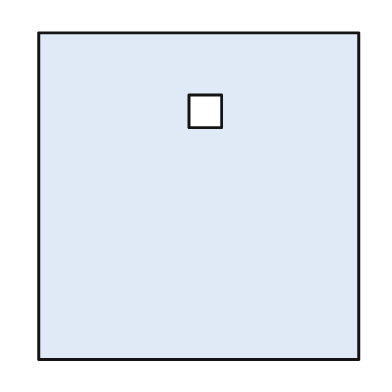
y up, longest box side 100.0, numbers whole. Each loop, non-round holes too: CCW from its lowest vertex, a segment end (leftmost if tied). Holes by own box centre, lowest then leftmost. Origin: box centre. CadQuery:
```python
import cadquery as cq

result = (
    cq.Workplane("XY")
    .moveTo(-49.0, -50.0)
    .lineTo(49.0, -50.0)
    .lineTo(49.0, 50.0)
    .lineTo(-49.0, 50.0)
    .close()
    .moveTo(-3.0, 21.0)
    .lineTo(7.0, 21.0)
    .lineTo(7.0, 31.0)
    .lineTo(-3.0, 31.0)
    .close()
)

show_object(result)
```